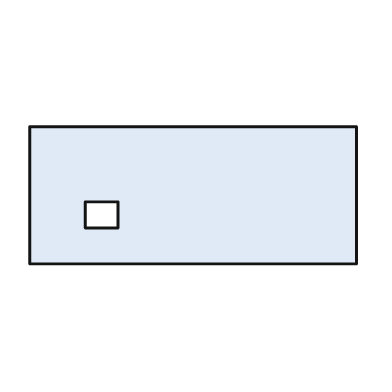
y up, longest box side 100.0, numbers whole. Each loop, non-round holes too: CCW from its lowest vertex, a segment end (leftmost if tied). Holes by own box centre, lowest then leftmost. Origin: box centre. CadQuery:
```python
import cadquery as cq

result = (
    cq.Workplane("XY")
    .moveTo(-50.0, -21.0)
    .lineTo(50.0, -21.0)
    .lineTo(50.0, 21.0)
    .lineTo(-50.0, 21.0)
    .close()
    .moveTo(-33.0, -10.0)
    .lineTo(-23.0, -10.0)
    .lineTo(-23.0, -2.0)
    .lineTo(-33.0, -2.0)
    .close()
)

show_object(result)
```